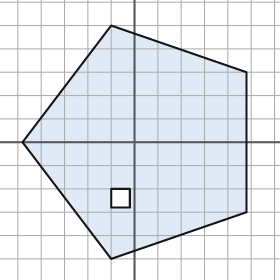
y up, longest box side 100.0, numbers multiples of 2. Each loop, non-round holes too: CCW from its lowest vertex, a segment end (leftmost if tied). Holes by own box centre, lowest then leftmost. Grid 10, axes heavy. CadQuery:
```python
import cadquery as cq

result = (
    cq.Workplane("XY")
    .moveTo(-10.0, -50.0)
    .lineTo(48.0, -30.0)
    .lineTo(48.0, 30.0)
    .lineTo(-10.0, 50.0)
    .lineTo(-48.0, 0.0)
    .close()
    .moveTo(-10.0, -28.0)
    .lineTo(-2.0, -28.0)
    .lineTo(-2.0, -20.0)
    .lineTo(-10.0, -20.0)
    .close()
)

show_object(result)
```